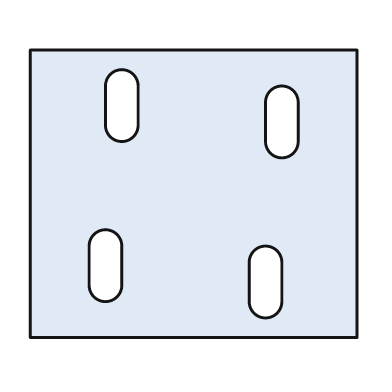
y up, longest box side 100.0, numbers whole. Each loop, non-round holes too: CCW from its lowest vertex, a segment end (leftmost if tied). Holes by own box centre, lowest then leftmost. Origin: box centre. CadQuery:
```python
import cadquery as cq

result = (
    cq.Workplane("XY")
    .moveTo(-50.0, -44.0)
    .lineTo(50.0, -44.0)
    .lineTo(50.0, 44.0)
    .lineTo(-50.0, 44.0)
    .close()
    .moveTo(17.0, -33.0)
    .threePointArc((22.0, -38.0), (27.0, -33.0))
    .lineTo(27.0, -21.0)
    .threePointArc((22.0, -16.0), (17.0, -21.0))
    .close()
    .moveTo(-32.0, -28.0)
    .threePointArc((-27.0, -33.0), (-22.0, -28.0))
    .lineTo(-22.0, -16.0)
    .threePointArc((-27.0, -11.0), (-32.0, -16.0))
    .close()
    .moveTo(22.0, 16.0)
    .threePointArc((27.0, 11.0), (32.0, 16.0))
    .lineTo(32.0, 28.0)
    .threePointArc((27.0, 33.0), (22.0, 28.0))
    .close()
    .moveTo(-27.0, 21.0)
    .threePointArc((-22.0, 16.0), (-17.0, 21.0))
    .lineTo(-17.0, 33.0)
    .threePointArc((-22.0, 38.0), (-27.0, 33.0))
    .close()
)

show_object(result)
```